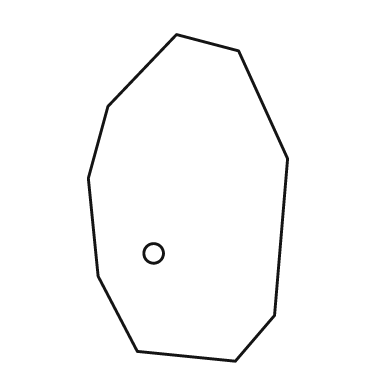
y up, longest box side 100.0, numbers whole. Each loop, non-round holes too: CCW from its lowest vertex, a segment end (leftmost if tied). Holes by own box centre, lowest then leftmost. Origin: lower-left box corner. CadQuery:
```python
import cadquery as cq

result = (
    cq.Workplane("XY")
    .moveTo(45.0, 0.0)
    .lineTo(57.0, 14.0)
    .lineTo(61.0, 62.0)
    .lineTo(46.0, 95.0)
    .lineTo(27.0, 100.0)
    .lineTo(6.0, 78.0)
    .lineTo(0.0, 56.0)
    .lineTo(3.0, 26.0)
    .lineTo(15.0, 3.0)
    .close()
    .moveTo(20.0, 33.0)
    .circle(3.0)
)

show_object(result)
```